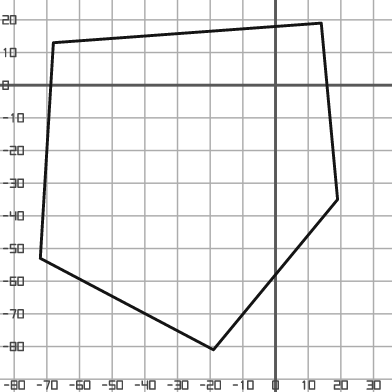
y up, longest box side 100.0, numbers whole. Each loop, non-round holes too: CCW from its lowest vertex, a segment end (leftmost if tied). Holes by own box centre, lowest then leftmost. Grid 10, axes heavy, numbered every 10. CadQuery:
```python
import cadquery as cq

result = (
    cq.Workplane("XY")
    .moveTo(-19.0, -81.0)
    .lineTo(19.0, -35.0)
    .lineTo(14.0, 19.0)
    .lineTo(-68.0, 13.0)
    .lineTo(-72.0, -53.0)
    .close()
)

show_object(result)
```